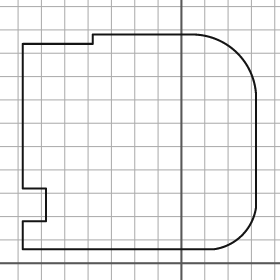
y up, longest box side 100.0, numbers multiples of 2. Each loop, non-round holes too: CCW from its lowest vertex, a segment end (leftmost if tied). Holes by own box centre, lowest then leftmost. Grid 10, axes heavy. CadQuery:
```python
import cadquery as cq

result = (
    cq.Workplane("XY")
    .moveTo(-68.0, 6.0)
    .lineTo(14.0, 6.0)
    .threePointArc((26.0, 12.0), (32.0, 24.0))
    .lineTo(32.0, 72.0)
    .threePointArc((24.0, 90.0), (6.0, 98.0))
    .lineTo(-38.0, 98.0)
    .lineTo(-38.0, 94.0)
    .lineTo(-68.0, 94.0)
    .lineTo(-68.0, 32.0)
    .lineTo(-58.0, 32.0)
    .lineTo(-58.0, 18.0)
    .lineTo(-68.0, 18.0)
    .close()
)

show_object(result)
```